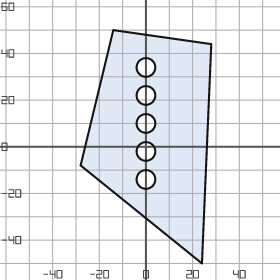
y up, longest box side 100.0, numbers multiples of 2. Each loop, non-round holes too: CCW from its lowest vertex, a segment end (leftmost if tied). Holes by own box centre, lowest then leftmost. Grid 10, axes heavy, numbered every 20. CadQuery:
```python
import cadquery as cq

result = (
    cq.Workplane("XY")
    .moveTo(24.0, -50.0)
    .lineTo(28.0, 44.0)
    .lineTo(-14.0, 50.0)
    .lineTo(-28.0, -8.0)
    .close()
    .moveTo(0.0, -14.0)
    .circle(4.0)
    .moveTo(0.0, -2.0)
    .circle(4.0)
    .moveTo(0.0, 10.0)
    .circle(4.0)
    .moveTo(0.0, 22.0)
    .circle(4.0)
    .moveTo(0.0, 34.0)
    .circle(4.0)
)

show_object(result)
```